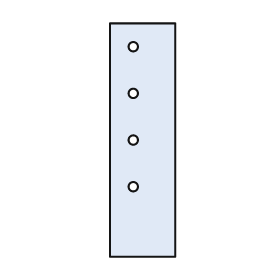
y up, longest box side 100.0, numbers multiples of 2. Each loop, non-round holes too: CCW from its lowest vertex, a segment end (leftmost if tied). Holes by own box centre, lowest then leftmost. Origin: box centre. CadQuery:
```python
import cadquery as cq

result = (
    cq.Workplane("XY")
    .moveTo(-14.0, -50.0)
    .lineTo(14.0, -50.0)
    .lineTo(14.0, 50.0)
    .lineTo(-14.0, 50.0)
    .close()
    .moveTo(-4.0, -20.0)
    .circle(2.0)
    .moveTo(-4.0, 0.0)
    .circle(2.0)
    .moveTo(-4.0, 20.0)
    .circle(2.0)
    .moveTo(-4.0, 40.0)
    .circle(2.0)
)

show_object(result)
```